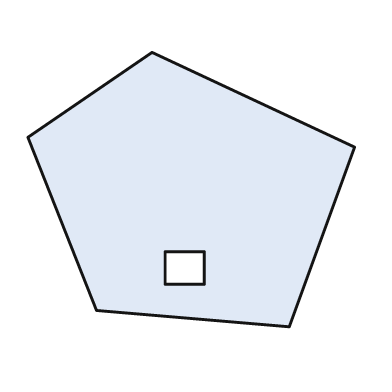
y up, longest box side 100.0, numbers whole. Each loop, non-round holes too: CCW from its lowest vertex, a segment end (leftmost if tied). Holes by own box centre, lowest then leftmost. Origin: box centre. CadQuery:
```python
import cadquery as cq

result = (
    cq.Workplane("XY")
    .moveTo(30.0, -42.0)
    .lineTo(50.0, 13.0)
    .lineTo(-12.0, 42.0)
    .lineTo(-50.0, 16.0)
    .lineTo(-29.0, -37.0)
    .close()
    .moveTo(-8.0, -29.0)
    .lineTo(4.0, -29.0)
    .lineTo(4.0, -19.0)
    .lineTo(-8.0, -19.0)
    .close()
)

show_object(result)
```